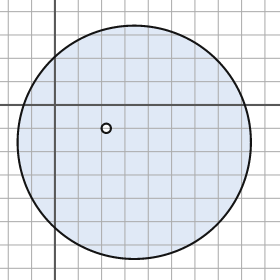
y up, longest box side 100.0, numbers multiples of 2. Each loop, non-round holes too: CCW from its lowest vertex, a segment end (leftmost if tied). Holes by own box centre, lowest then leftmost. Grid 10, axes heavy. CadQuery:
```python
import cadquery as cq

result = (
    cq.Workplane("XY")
    .moveTo(34.0, -16.0)
    .circle(50.0)
    .moveTo(22.0, -10.0)
    .circle(2.0)
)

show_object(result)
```